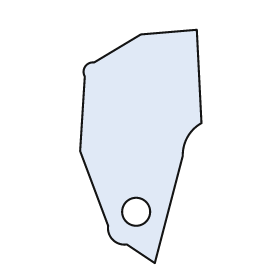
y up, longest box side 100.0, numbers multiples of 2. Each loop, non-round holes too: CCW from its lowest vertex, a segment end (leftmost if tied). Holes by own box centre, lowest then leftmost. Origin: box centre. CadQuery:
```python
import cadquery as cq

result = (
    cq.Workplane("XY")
    .moveTo(6.0, -50.0)
    .lineTo(18.0, -4.0)
    .threePointArc((20.0, 4.0), (26.0, 10.0))
    .lineTo(24.0, 50.0)
    .lineTo(0.0, 48.0)
    .lineTo(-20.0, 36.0)
    .threePointArc((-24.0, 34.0), (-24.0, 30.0))
    .lineTo(-26.0, -2.0)
    .lineTo(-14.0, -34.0)
    .threePointArc((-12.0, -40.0), (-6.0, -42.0))
    .close()
    .moveTo(-2.0, -28.0)
    .circle(6.0)
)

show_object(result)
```